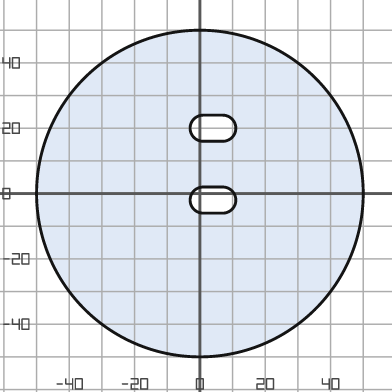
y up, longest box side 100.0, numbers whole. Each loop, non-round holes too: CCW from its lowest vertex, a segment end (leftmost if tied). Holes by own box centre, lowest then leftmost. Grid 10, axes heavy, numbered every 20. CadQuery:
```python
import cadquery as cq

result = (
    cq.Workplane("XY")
    .moveTo(0.0, 0.0)
    .circle(50.0)
    .moveTo(1.0, -6.0)
    .lineTo(7.0, -6.0)
    .threePointArc((11.0, -2.0), (7.0, 2.0))
    .lineTo(1.0, 2.0)
    .threePointArc((-3.0, -2.0), (1.0, -6.0))
    .close()
    .moveTo(1.0, 16.0)
    .lineTo(7.0, 16.0)
    .threePointArc((11.0, 20.0), (7.0, 24.0))
    .lineTo(1.0, 24.0)
    .threePointArc((-3.0, 20.0), (1.0, 16.0))
    .close()
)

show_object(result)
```